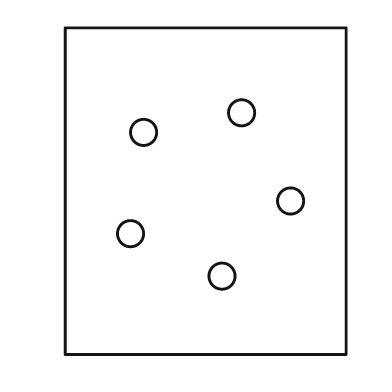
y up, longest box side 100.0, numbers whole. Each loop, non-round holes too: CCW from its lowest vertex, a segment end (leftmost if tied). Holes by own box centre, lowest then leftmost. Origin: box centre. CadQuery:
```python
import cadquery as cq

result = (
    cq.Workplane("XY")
    .moveTo(-43.0, -50.0)
    .lineTo(43.0, -50.0)
    .lineTo(43.0, 50.0)
    .lineTo(-43.0, 50.0)
    .close()
    .moveTo(5.0, -26.0)
    .circle(4.0)
    .moveTo(-23.0, -13.0)
    .circle(4.0)
    .moveTo(26.0, -3.0)
    .circle(4.0)
    .moveTo(-19.0, 18.0)
    .circle(4.0)
    .moveTo(11.0, 24.0)
    .circle(4.0)
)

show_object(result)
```